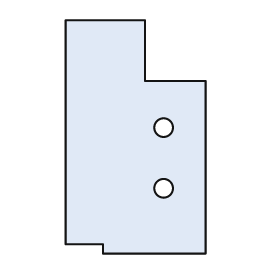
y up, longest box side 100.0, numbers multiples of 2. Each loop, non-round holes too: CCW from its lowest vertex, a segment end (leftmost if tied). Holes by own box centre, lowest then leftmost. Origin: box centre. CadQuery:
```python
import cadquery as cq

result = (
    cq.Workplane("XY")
    .moveTo(-14.0, -50.0)
    .lineTo(30.0, -50.0)
    .lineTo(30.0, 24.0)
    .lineTo(4.0, 24.0)
    .lineTo(4.0, 50.0)
    .lineTo(-30.0, 50.0)
    .lineTo(-30.0, -46.0)
    .lineTo(-14.0, -46.0)
    .close()
    .moveTo(12.0, -22.0)
    .circle(4.0)
    .moveTo(12.0, 4.0)
    .circle(4.0)
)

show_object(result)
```